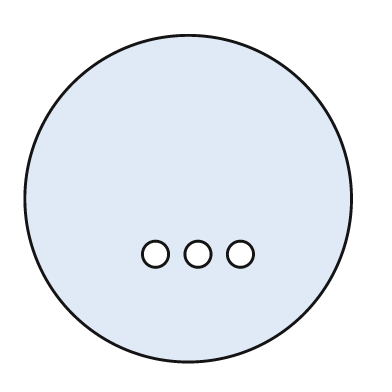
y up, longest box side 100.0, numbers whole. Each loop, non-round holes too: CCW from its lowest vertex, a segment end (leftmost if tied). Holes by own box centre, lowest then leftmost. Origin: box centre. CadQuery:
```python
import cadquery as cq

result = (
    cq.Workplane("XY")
    .moveTo(0.0, 0.0)
    .circle(50.0)
    .moveTo(-10.0, -17.0)
    .circle(4.0)
    .moveTo(3.0, -17.0)
    .circle(4.0)
    .moveTo(16.0, -17.0)
    .circle(4.0)
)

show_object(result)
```